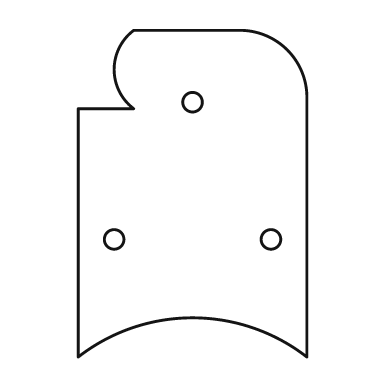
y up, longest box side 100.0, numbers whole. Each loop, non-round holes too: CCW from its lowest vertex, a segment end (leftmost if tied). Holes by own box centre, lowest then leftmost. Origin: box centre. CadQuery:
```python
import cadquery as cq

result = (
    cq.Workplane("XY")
    .moveTo(-35.0, -50.0)
    .threePointArc((0.0, -38.0), (35.0, -50.0))
    .lineTo(35.0, 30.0)
    .threePointArc((29.0, 44.0), (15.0, 50.0))
    .lineTo(-18.0, 50.0)
    .threePointArc((-24.0, 38.0), (-18.0, 26.0))
    .lineTo(-35.0, 26.0)
    .close()
    .moveTo(-24.0, -14.0)
    .circle(3.0)
    .moveTo(24.0, -14.0)
    .circle(3.0)
    .moveTo(0.0, 28.0)
    .circle(3.0)
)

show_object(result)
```